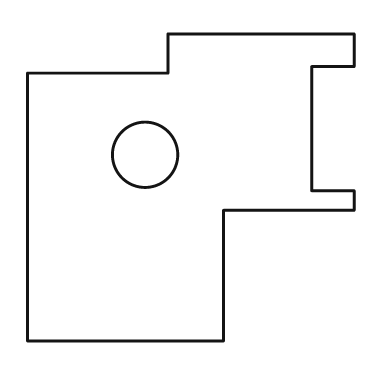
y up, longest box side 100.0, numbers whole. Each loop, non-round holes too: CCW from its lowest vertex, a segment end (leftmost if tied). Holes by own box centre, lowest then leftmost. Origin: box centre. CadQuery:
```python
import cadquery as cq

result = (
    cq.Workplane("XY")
    .moveTo(-50.0, -47.0)
    .lineTo(10.0, -47.0)
    .lineTo(10.0, -7.0)
    .lineTo(50.0, -7.0)
    .lineTo(50.0, -1.0)
    .lineTo(37.0, -1.0)
    .lineTo(37.0, 37.0)
    .lineTo(50.0, 37.0)
    .lineTo(50.0, 47.0)
    .lineTo(-7.0, 47.0)
    .lineTo(-7.0, 35.0)
    .lineTo(-50.0, 35.0)
    .close()
    .moveTo(-14.0, 10.0)
    .circle(10.0)
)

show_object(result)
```